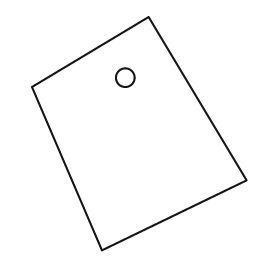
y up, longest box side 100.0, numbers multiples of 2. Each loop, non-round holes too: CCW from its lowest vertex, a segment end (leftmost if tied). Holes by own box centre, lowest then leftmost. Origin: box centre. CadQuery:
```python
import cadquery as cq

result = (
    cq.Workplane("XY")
    .moveTo(-16.0, -50.0)
    .lineTo(46.0, -20.0)
    .lineTo(4.0, 50.0)
    .lineTo(-46.0, 20.0)
    .close()
    .moveTo(-6.0, 24.0)
    .circle(4.0)
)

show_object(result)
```